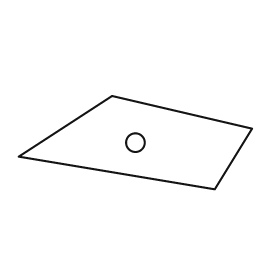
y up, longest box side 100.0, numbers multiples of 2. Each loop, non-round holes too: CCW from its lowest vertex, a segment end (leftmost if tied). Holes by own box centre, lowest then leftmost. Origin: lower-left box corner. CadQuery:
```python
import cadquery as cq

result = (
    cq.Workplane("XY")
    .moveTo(84.0, 0.0)
    .lineTo(100.0, 26.0)
    .lineTo(40.0, 40.0)
    .lineTo(0.0, 14.0)
    .close()
    .moveTo(50.0, 20.0)
    .circle(4.0)
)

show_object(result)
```